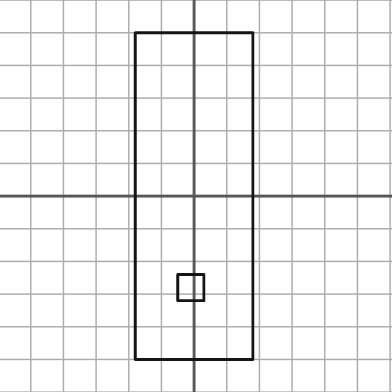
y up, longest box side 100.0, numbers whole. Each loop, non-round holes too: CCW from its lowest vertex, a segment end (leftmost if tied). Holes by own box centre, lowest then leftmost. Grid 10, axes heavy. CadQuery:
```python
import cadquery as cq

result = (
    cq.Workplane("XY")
    .moveTo(-18.0, -50.0)
    .lineTo(18.0, -50.0)
    .lineTo(18.0, 50.0)
    .lineTo(-18.0, 50.0)
    .close()
    .moveTo(-5.0, -32.0)
    .lineTo(3.0, -32.0)
    .lineTo(3.0, -24.0)
    .lineTo(-5.0, -24.0)
    .close()
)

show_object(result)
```